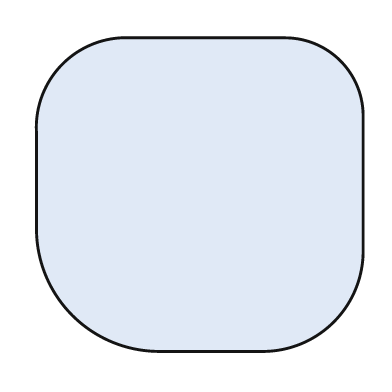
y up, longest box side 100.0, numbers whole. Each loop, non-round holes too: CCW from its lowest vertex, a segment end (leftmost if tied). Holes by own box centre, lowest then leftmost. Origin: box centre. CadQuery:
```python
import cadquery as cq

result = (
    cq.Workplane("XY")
    .moveTo(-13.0, -48.0)
    .lineTo(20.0, -48.0)
    .threePointArc((41.0, -39.0), (50.0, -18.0))
    .lineTo(50.0, 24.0)
    .threePointArc((43.0, 41.0), (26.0, 48.0))
    .lineTo(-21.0, 48.0)
    .threePointArc((-42.0, 40.0), (-50.0, 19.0))
    .lineTo(-50.0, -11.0)
    .threePointArc((-39.0, -37.0), (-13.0, -48.0))
    .close()
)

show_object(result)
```